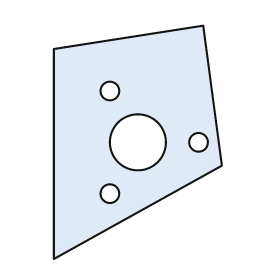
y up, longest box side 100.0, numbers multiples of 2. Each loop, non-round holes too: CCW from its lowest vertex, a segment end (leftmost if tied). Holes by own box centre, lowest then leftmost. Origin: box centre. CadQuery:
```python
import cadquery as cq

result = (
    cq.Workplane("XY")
    .moveTo(-36.0, -50.0)
    .lineTo(36.0, -10.0)
    .lineTo(28.0, 50.0)
    .lineTo(-36.0, 40.0)
    .close()
    .moveTo(-12.0, -22.0)
    .circle(4.0)
    .moveTo(0.0, 0.0)
    .circle(12.0)
    .moveTo(26.0, 0.0)
    .circle(4.0)
    .moveTo(-12.0, 22.0)
    .circle(4.0)
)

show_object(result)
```